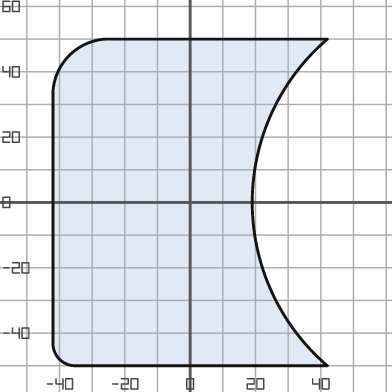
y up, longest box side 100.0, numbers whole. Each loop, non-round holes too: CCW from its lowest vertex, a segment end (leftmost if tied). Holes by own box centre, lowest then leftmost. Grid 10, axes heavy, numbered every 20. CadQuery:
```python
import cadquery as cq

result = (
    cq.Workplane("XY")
    .moveTo(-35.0, -50.0)
    .lineTo(42.0, -50.0)
    .threePointArc((19.0, 0.0), (42.0, 50.0))
    .lineTo(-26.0, 50.0)
    .threePointArc((-37.0, 45.0), (-42.0, 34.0))
    .lineTo(-42.0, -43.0)
    .threePointArc((-40.0, -48.0), (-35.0, -50.0))
    .close()
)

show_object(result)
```